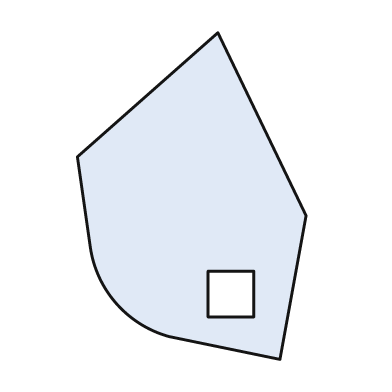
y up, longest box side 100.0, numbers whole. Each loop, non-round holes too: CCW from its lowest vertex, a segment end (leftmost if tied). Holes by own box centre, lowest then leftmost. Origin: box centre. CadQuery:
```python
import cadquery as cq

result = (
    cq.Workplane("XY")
    .moveTo(27.0, -50.0)
    .lineTo(35.0, -6.0)
    .lineTo(8.0, 50.0)
    .lineTo(-35.0, 12.0)
    .lineTo(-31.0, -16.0)
    .threePointArc((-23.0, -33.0), (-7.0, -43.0))
    .close()
    .moveTo(5.0, -37.0)
    .lineTo(19.0, -37.0)
    .lineTo(19.0, -23.0)
    .lineTo(5.0, -23.0)
    .close()
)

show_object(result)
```